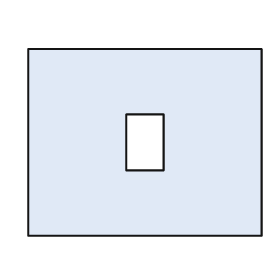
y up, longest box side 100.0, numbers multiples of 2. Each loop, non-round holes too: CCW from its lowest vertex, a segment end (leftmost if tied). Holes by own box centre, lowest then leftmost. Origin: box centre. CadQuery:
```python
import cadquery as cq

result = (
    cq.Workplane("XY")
    .moveTo(-50.0, -40.0)
    .lineTo(50.0, -40.0)
    .lineTo(50.0, 40.0)
    .lineTo(-50.0, 40.0)
    .close()
    .moveTo(-8.0, -12.0)
    .lineTo(8.0, -12.0)
    .lineTo(8.0, 12.0)
    .lineTo(-8.0, 12.0)
    .close()
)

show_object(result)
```